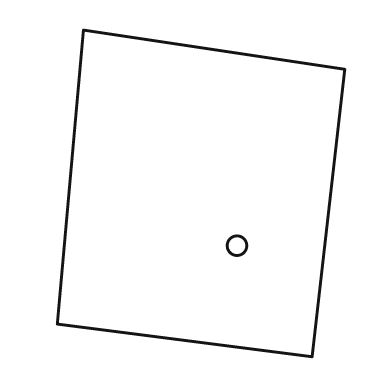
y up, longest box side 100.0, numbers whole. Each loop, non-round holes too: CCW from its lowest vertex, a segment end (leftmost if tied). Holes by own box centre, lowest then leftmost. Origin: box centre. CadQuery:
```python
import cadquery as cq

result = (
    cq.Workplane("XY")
    .moveTo(34.0, -50.0)
    .lineTo(44.0, 38.0)
    .lineTo(-36.0, 50.0)
    .lineTo(-44.0, -40.0)
    .close()
    .moveTo(11.0, -16.0)
    .circle(3.0)
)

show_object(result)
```